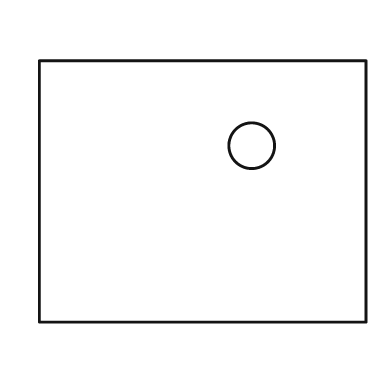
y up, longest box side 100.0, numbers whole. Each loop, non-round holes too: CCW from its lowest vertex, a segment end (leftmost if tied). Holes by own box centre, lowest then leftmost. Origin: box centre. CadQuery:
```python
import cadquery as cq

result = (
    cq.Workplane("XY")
    .moveTo(-50.0, -40.0)
    .lineTo(50.0, -40.0)
    .lineTo(50.0, 40.0)
    .lineTo(-50.0, 40.0)
    .close()
    .moveTo(15.0, 14.0)
    .circle(7.0)
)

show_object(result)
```